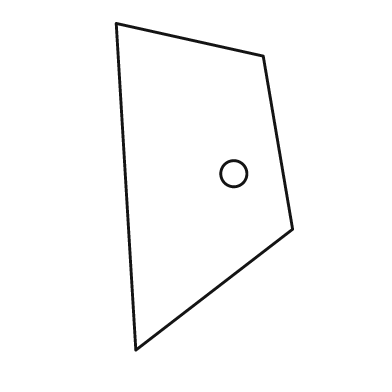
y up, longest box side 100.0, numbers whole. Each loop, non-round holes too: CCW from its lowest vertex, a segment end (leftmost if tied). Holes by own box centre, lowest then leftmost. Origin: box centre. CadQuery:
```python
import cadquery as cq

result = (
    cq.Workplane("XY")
    .moveTo(-21.0, -50.0)
    .lineTo(27.0, -13.0)
    .lineTo(18.0, 40.0)
    .lineTo(-27.0, 50.0)
    .close()
    .moveTo(9.0, 4.0)
    .circle(4.0)
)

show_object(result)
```